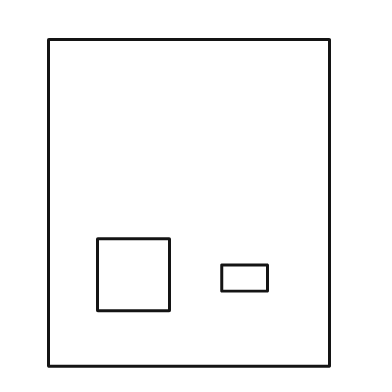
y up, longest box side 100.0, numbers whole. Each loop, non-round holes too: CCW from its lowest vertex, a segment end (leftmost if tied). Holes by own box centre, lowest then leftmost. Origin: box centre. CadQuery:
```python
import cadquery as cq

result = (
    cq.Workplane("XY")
    .moveTo(-43.0, -50.0)
    .lineTo(43.0, -50.0)
    .lineTo(43.0, 50.0)
    .lineTo(-43.0, 50.0)
    .close()
    .moveTo(10.0, -27.0)
    .lineTo(24.0, -27.0)
    .lineTo(24.0, -19.0)
    .lineTo(10.0, -19.0)
    .close()
    .moveTo(-28.0, -33.0)
    .lineTo(-6.0, -33.0)
    .lineTo(-6.0, -11.0)
    .lineTo(-28.0, -11.0)
    .close()
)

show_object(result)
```